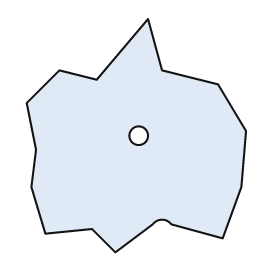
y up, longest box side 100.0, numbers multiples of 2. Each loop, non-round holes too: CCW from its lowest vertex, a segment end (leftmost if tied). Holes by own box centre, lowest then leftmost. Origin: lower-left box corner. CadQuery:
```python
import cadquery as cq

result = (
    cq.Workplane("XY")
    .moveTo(38.0, 0.0)
    .lineTo(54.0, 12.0)
    .threePointArc((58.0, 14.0), (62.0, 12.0))
    .lineTo(84.0, 6.0)
    .lineTo(92.0, 28.0)
    .lineTo(94.0, 52.0)
    .lineTo(82.0, 72.0)
    .lineTo(58.0, 78.0)
    .lineTo(52.0, 100.0)
    .lineTo(30.0, 74.0)
    .lineTo(14.0, 78.0)
    .lineTo(0.0, 64.0)
    .lineTo(4.0, 44.0)
    .lineTo(2.0, 28.0)
    .lineTo(8.0, 8.0)
    .lineTo(28.0, 10.0)
    .close()
    .moveTo(48.0, 50.0)
    .circle(4.0)
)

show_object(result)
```